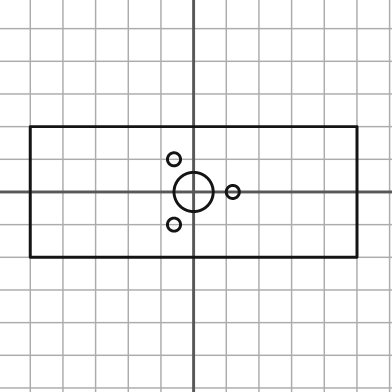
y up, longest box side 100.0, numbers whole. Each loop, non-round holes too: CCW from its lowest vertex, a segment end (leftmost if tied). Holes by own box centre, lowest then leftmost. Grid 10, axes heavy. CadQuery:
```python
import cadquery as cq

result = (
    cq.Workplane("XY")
    .moveTo(-50.0, -20.0)
    .lineTo(50.0, -20.0)
    .lineTo(50.0, 20.0)
    .lineTo(-50.0, 20.0)
    .close()
    .moveTo(-6.0, -10.0)
    .circle(2.0)
    .moveTo(0.0, 0.0)
    .circle(6.0)
    .moveTo(12.0, 0.0)
    .circle(2.0)
    .moveTo(-6.0, 10.0)
    .circle(2.0)
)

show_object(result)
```